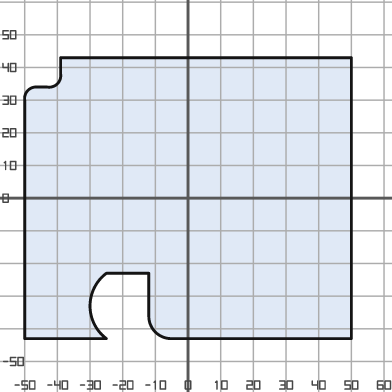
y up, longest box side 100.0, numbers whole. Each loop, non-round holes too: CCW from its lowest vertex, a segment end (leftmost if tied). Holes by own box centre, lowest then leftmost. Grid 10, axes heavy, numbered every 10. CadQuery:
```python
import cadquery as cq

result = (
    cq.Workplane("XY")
    .moveTo(-50.0, -43.0)
    .lineTo(-25.0, -43.0)
    .threePointArc((-30.0, -33.0), (-25.0, -23.0))
    .lineTo(-12.0, -23.0)
    .lineTo(-12.0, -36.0)
    .threePointArc((-10.0, -41.0), (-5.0, -43.0))
    .lineTo(50.0, -43.0)
    .lineTo(50.0, 43.0)
    .lineTo(-39.0, 43.0)
    .lineTo(-39.0, 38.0)
    .threePointArc((-40.0, 35.0), (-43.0, 34.0))
    .lineTo(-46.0, 34.0)
    .threePointArc((-49.0, 33.0), (-50.0, 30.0))
    .close()
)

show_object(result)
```